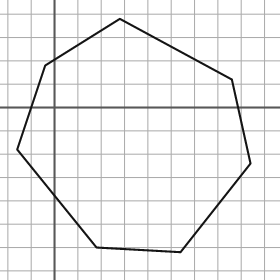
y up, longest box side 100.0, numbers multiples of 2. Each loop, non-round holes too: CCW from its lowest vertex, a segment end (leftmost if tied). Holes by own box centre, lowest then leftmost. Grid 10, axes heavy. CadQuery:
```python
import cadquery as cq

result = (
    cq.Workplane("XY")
    .moveTo(54.0, -62.0)
    .lineTo(84.0, -24.0)
    .lineTo(76.0, 12.0)
    .lineTo(28.0, 38.0)
    .lineTo(-4.0, 18.0)
    .lineTo(-16.0, -18.0)
    .lineTo(18.0, -60.0)
    .close()
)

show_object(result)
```